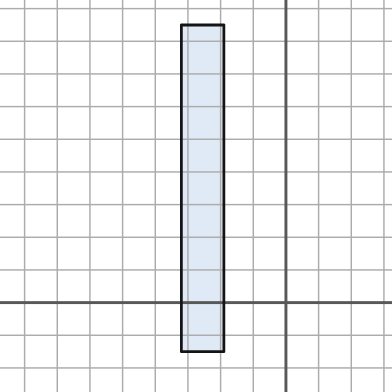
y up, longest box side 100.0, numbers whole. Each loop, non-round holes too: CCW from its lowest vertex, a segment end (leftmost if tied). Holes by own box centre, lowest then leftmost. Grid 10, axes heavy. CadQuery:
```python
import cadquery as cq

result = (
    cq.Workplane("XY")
    .moveTo(-32.0, -15.0)
    .lineTo(-19.0, -15.0)
    .lineTo(-19.0, 85.0)
    .lineTo(-32.0, 85.0)
    .close()
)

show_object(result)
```